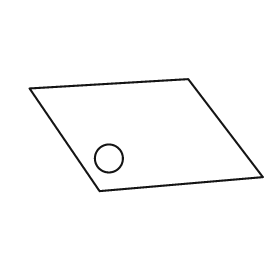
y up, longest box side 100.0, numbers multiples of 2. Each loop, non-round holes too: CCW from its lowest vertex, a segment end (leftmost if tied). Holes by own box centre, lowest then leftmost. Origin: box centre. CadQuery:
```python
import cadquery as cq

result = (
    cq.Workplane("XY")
    .moveTo(-20.0, -24.0)
    .lineTo(50.0, -18.0)
    .lineTo(18.0, 24.0)
    .lineTo(-50.0, 20.0)
    .close()
    .moveTo(-16.0, -10.0)
    .circle(6.0)
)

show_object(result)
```